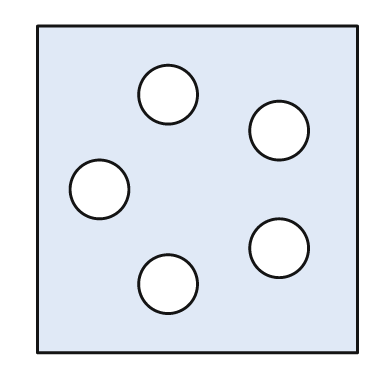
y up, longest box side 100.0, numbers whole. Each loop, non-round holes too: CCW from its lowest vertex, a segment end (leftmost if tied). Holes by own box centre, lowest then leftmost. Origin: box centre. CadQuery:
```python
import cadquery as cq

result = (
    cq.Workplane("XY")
    .moveTo(-49.0, -50.0)
    .lineTo(49.0, -50.0)
    .lineTo(49.0, 50.0)
    .lineTo(-49.0, 50.0)
    .close()
    .moveTo(-9.0, -29.0)
    .circle(9.0)
    .moveTo(25.0, -18.0)
    .circle(9.0)
    .moveTo(-30.0, 0.0)
    .circle(9.0)
    .moveTo(25.0, 18.0)
    .circle(9.0)
    .moveTo(-9.0, 29.0)
    .circle(9.0)
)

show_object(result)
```